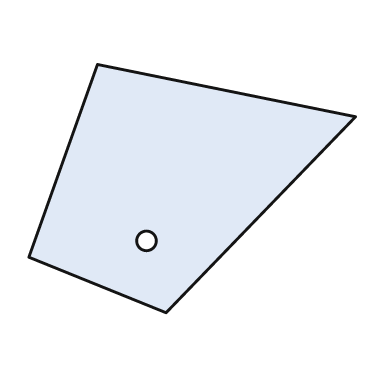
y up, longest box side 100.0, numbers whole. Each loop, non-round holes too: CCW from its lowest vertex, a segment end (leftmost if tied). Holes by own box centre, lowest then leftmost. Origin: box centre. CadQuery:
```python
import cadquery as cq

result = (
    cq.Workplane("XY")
    .moveTo(-8.0, -38.0)
    .lineTo(50.0, 22.0)
    .lineTo(-29.0, 38.0)
    .lineTo(-50.0, -21.0)
    .close()
    .moveTo(-14.0, -16.0)
    .circle(3.0)
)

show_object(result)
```